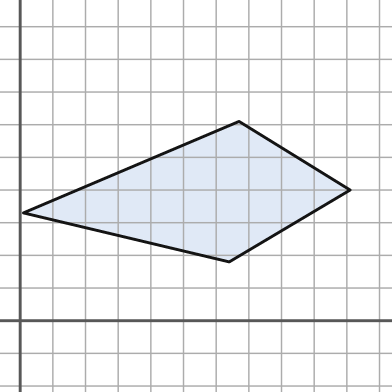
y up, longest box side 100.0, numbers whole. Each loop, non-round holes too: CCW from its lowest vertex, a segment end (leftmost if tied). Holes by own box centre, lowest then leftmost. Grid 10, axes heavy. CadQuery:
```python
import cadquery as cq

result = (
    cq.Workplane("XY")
    .moveTo(64.0, 18.0)
    .lineTo(101.0, 40.0)
    .lineTo(67.0, 61.0)
    .lineTo(1.0, 33.0)
    .close()
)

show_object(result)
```